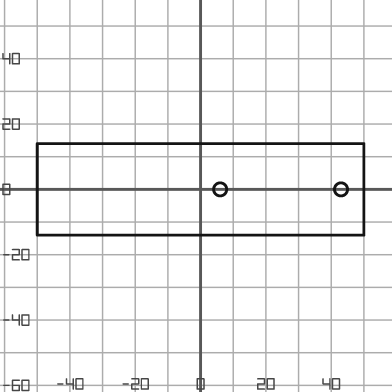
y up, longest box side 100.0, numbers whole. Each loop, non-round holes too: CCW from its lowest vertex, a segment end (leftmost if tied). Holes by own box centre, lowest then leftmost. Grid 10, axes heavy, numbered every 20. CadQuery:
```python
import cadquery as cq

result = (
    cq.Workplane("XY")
    .moveTo(-50.0, -14.0)
    .lineTo(50.0, -14.0)
    .lineTo(50.0, 14.0)
    .lineTo(-50.0, 14.0)
    .close()
    .moveTo(6.0, 0.0)
    .circle(2.0)
    .moveTo(43.0, 0.0)
    .circle(2.0)
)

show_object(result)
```